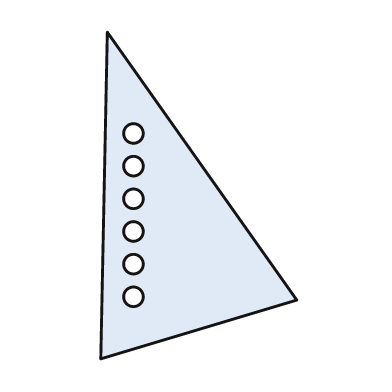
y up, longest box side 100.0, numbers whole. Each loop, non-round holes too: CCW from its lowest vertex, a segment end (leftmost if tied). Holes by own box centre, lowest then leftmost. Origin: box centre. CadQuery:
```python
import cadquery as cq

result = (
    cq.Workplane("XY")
    .moveTo(-30.0, -50.0)
    .lineTo(30.0, -32.0)
    .lineTo(-28.0, 50.0)
    .close()
    .moveTo(-20.0, -31.0)
    .circle(3.0)
    .moveTo(-20.0, -21.0)
    .circle(3.0)
    .moveTo(-20.0, -11.0)
    .circle(3.0)
    .moveTo(-20.0, -1.0)
    .circle(3.0)
    .moveTo(-20.0, 9.0)
    .circle(3.0)
    .moveTo(-20.0, 19.0)
    .circle(3.0)
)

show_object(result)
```